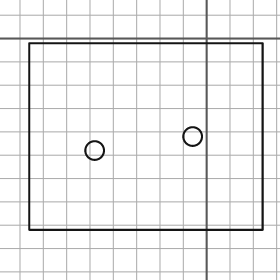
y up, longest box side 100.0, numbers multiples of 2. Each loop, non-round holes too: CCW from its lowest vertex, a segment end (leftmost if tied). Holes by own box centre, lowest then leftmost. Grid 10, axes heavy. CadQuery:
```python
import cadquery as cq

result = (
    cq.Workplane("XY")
    .moveTo(-76.0, -82.0)
    .lineTo(24.0, -82.0)
    .lineTo(24.0, -2.0)
    .lineTo(-76.0, -2.0)
    .close()
    .moveTo(-48.0, -48.0)
    .circle(4.0)
    .moveTo(-6.0, -42.0)
    .circle(4.0)
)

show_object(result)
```